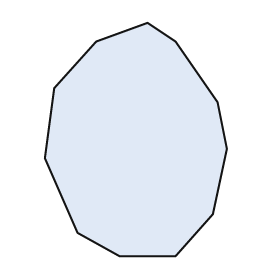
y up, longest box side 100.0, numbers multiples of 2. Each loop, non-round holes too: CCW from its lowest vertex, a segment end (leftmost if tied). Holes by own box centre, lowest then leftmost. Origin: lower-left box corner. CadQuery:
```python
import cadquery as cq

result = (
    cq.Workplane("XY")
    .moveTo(32.0, 0.0)
    .lineTo(56.0, 0.0)
    .lineTo(72.0, 18.0)
    .lineTo(78.0, 46.0)
    .lineTo(74.0, 66.0)
    .lineTo(56.0, 92.0)
    .lineTo(44.0, 100.0)
    .lineTo(22.0, 92.0)
    .lineTo(4.0, 72.0)
    .lineTo(0.0, 42.0)
    .lineTo(14.0, 10.0)
    .close()
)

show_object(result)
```